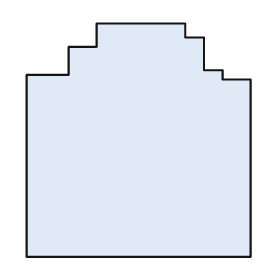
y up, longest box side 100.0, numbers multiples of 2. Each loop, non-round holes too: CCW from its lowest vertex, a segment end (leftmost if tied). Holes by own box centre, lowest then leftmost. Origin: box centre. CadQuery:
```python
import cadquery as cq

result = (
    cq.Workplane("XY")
    .moveTo(-48.0, -50.0)
    .lineTo(48.0, -50.0)
    .lineTo(48.0, 26.0)
    .lineTo(36.0, 26.0)
    .lineTo(36.0, 30.0)
    .lineTo(28.0, 30.0)
    .lineTo(28.0, 44.0)
    .lineTo(20.0, 44.0)
    .lineTo(20.0, 50.0)
    .lineTo(-18.0, 50.0)
    .lineTo(-18.0, 40.0)
    .lineTo(-30.0, 40.0)
    .lineTo(-30.0, 28.0)
    .lineTo(-48.0, 28.0)
    .close()
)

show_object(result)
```